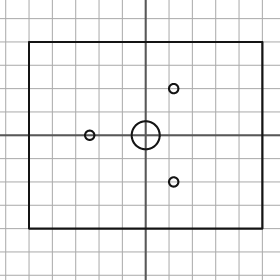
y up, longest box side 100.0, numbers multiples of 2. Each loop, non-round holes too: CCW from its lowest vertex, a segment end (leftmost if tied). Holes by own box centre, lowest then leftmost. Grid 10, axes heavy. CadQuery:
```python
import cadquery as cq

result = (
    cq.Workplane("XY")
    .moveTo(-50.0, -40.0)
    .lineTo(50.0, -40.0)
    .lineTo(50.0, 40.0)
    .lineTo(-50.0, 40.0)
    .close()
    .moveTo(12.0, -20.0)
    .circle(2.0)
    .moveTo(-24.0, 0.0)
    .circle(2.0)
    .moveTo(0.0, 0.0)
    .circle(6.0)
    .moveTo(12.0, 20.0)
    .circle(2.0)
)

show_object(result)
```